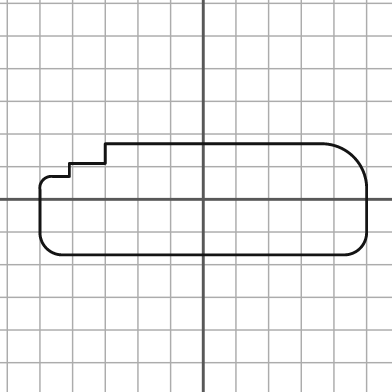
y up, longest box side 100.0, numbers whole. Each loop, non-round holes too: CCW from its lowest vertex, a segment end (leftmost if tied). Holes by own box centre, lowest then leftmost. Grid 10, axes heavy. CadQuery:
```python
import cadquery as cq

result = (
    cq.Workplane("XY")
    .moveTo(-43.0, -17.0)
    .lineTo(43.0, -17.0)
    .threePointArc((48.0, -15.0), (50.0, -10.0))
    .lineTo(50.0, 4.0)
    .threePointArc((46.0, 13.0), (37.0, 17.0))
    .lineTo(-30.0, 17.0)
    .lineTo(-30.0, 11.0)
    .lineTo(-41.0, 11.0)
    .lineTo(-41.0, 7.0)
    .lineTo(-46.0, 7.0)
    .threePointArc((-49.0, 6.0), (-50.0, 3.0))
    .lineTo(-50.0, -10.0)
    .threePointArc((-48.0, -15.0), (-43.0, -17.0))
    .close()
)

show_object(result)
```